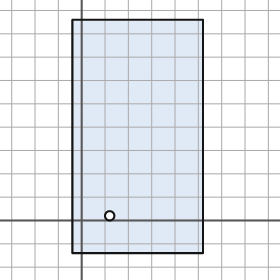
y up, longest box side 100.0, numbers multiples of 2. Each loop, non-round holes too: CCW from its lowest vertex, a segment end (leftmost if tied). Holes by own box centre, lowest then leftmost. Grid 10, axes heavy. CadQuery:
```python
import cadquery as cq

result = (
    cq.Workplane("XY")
    .moveTo(-4.0, -14.0)
    .lineTo(52.0, -14.0)
    .lineTo(52.0, 86.0)
    .lineTo(-4.0, 86.0)
    .close()
    .moveTo(12.0, 2.0)
    .circle(2.0)
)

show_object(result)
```